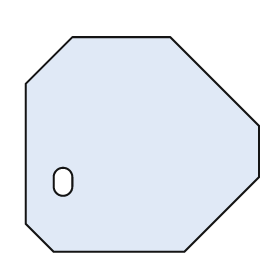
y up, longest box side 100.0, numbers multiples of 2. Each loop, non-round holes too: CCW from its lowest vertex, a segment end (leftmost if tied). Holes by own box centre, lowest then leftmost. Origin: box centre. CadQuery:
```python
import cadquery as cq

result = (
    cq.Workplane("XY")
    .moveTo(-38.0, -46.0)
    .lineTo(18.0, -46.0)
    .lineTo(50.0, -14.0)
    .lineTo(50.0, 8.0)
    .lineTo(12.0, 46.0)
    .lineTo(-30.0, 46.0)
    .lineTo(-50.0, 26.0)
    .lineTo(-50.0, -34.0)
    .close()
    .moveTo(-38.0, -18.0)
    .threePointArc((-34.0, -22.0), (-30.0, -18.0))
    .lineTo(-30.0, -14.0)
    .threePointArc((-34.0, -10.0), (-38.0, -14.0))
    .close()
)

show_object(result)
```